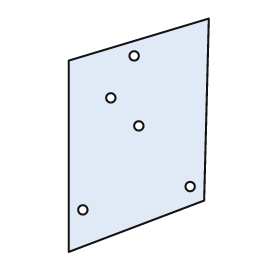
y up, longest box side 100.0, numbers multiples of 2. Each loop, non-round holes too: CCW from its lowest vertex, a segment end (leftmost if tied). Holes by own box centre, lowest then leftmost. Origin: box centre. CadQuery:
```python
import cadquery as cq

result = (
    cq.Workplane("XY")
    .moveTo(-30.0, -50.0)
    .lineTo(28.0, -28.0)
    .lineTo(30.0, 50.0)
    .lineTo(-30.0, 32.0)
    .close()
    .moveTo(-24.0, -32.0)
    .circle(2.0)
    .moveTo(22.0, -22.0)
    .circle(2.0)
    .moveTo(0.0, 4.0)
    .circle(2.0)
    .moveTo(-12.0, 16.0)
    .circle(2.0)
    .moveTo(-2.0, 34.0)
    .circle(2.0)
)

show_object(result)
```